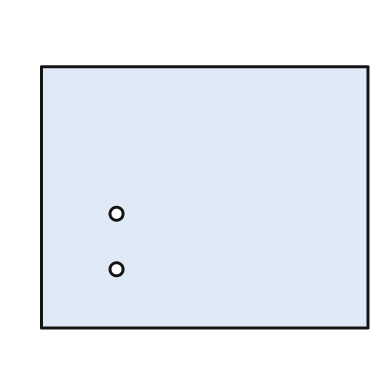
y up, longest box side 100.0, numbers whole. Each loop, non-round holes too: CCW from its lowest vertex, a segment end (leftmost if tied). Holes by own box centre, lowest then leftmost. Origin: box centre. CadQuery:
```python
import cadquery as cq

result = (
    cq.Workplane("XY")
    .moveTo(-50.0, -40.0)
    .lineTo(50.0, -40.0)
    .lineTo(50.0, 40.0)
    .lineTo(-50.0, 40.0)
    .close()
    .moveTo(-27.0, -22.0)
    .circle(2.0)
    .moveTo(-27.0, -5.0)
    .circle(2.0)
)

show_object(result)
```